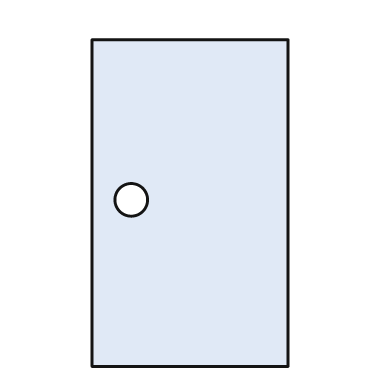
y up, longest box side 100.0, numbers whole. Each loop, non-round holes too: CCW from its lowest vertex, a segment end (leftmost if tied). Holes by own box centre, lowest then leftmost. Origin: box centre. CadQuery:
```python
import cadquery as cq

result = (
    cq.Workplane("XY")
    .moveTo(-30.0, -50.0)
    .lineTo(30.0, -50.0)
    .lineTo(30.0, 50.0)
    .lineTo(-30.0, 50.0)
    .close()
    .moveTo(-18.0, 1.0)
    .circle(5.0)
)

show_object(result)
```